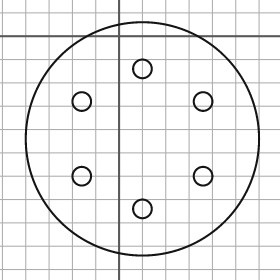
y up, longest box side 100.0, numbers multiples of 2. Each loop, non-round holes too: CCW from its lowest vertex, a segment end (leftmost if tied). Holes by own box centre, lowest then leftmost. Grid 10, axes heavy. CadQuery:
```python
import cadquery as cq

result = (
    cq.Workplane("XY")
    .moveTo(10.0, -44.0)
    .circle(50.0)
    .moveTo(10.0, -74.0)
    .circle(4.0)
    .moveTo(-16.0, -60.0)
    .circle(4.0)
    .moveTo(36.0, -60.0)
    .circle(4.0)
    .moveTo(-16.0, -28.0)
    .circle(4.0)
    .moveTo(36.0, -28.0)
    .circle(4.0)
    .moveTo(10.0, -14.0)
    .circle(4.0)
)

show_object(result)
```